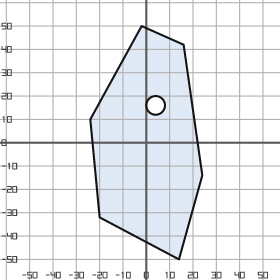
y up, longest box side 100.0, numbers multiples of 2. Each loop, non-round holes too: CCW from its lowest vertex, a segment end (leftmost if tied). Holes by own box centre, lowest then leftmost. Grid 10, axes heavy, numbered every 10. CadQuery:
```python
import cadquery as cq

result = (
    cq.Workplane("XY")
    .moveTo(14.0, -50.0)
    .lineTo(24.0, -14.0)
    .lineTo(16.0, 42.0)
    .lineTo(-2.0, 50.0)
    .lineTo(-24.0, 10.0)
    .lineTo(-20.0, -32.0)
    .close()
    .moveTo(4.0, 16.0)
    .circle(4.0)
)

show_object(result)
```